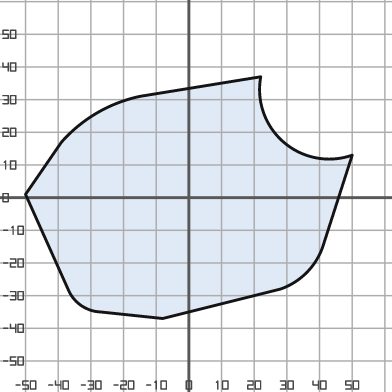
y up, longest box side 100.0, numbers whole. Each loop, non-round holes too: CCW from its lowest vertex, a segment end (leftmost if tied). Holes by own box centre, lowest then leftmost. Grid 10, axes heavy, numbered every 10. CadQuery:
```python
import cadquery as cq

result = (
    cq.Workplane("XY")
    .moveTo(-8.0, -37.0)
    .lineTo(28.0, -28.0)
    .threePointArc((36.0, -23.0), (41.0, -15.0))
    .lineTo(50.0, 13.0)
    .threePointArc((29.0, 17.0), (22.0, 37.0))
    .lineTo(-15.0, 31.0)
    .threePointArc((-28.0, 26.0), (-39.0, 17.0))
    .lineTo(-50.0, 1.0)
    .lineTo(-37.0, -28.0)
    .threePointArc((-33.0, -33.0), (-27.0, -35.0))
    .close()
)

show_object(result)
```